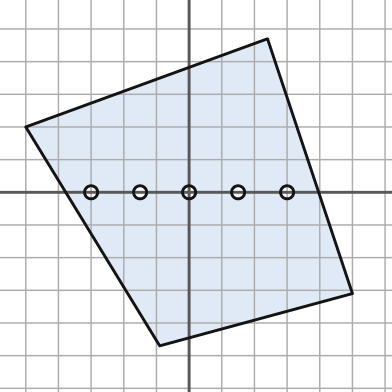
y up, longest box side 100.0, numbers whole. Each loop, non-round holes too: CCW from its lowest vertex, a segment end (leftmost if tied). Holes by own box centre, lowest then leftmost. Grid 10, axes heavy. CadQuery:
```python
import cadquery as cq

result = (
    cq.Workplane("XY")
    .moveTo(-9.0, -47.0)
    .lineTo(50.0, -31.0)
    .lineTo(24.0, 47.0)
    .lineTo(-50.0, 20.0)
    .close()
    .moveTo(-30.0, 0.0)
    .circle(2.0)
    .moveTo(-15.0, 0.0)
    .circle(2.0)
    .moveTo(0.0, 0.0)
    .circle(2.0)
    .moveTo(15.0, 0.0)
    .circle(2.0)
    .moveTo(30.0, 0.0)
    .circle(2.0)
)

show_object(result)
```